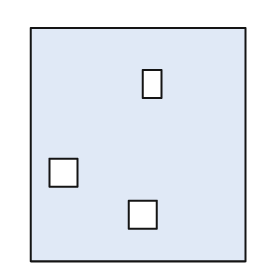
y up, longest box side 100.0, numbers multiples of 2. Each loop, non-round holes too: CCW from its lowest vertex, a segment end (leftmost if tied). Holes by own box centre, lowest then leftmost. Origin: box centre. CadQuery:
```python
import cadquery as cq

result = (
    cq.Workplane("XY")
    .moveTo(-46.0, -50.0)
    .lineTo(46.0, -50.0)
    .lineTo(46.0, 50.0)
    .lineTo(-46.0, 50.0)
    .close()
    .moveTo(-4.0, -36.0)
    .lineTo(8.0, -36.0)
    .lineTo(8.0, -24.0)
    .lineTo(-4.0, -24.0)
    .close()
    .moveTo(-38.0, -18.0)
    .lineTo(-26.0, -18.0)
    .lineTo(-26.0, -6.0)
    .lineTo(-38.0, -6.0)
    .close()
    .moveTo(2.0, 20.0)
    .lineTo(10.0, 20.0)
    .lineTo(10.0, 32.0)
    .lineTo(2.0, 32.0)
    .close()
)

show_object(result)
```